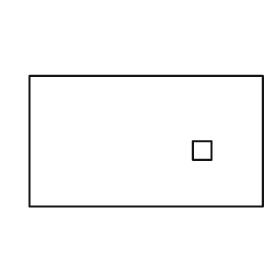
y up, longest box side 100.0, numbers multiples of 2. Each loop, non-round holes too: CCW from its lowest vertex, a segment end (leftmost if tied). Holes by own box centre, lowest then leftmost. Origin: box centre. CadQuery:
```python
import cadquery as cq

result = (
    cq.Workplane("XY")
    .moveTo(-50.0, -28.0)
    .lineTo(50.0, -28.0)
    .lineTo(50.0, 28.0)
    .lineTo(-50.0, 28.0)
    .close()
    .moveTo(20.0, -8.0)
    .lineTo(28.0, -8.0)
    .lineTo(28.0, 0.0)
    .lineTo(20.0, 0.0)
    .close()
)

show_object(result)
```